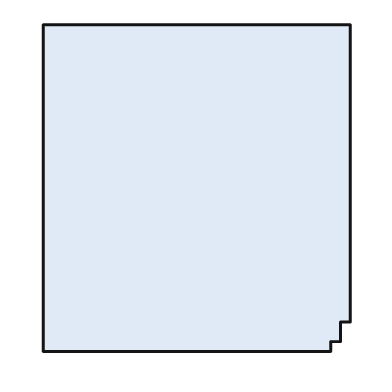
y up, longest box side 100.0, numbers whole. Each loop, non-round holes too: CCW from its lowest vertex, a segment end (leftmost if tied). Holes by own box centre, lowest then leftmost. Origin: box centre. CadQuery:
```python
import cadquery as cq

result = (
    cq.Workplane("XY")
    .moveTo(-47.0, -50.0)
    .lineTo(41.0, -50.0)
    .lineTo(41.0, -47.0)
    .lineTo(44.0, -47.0)
    .lineTo(44.0, -41.0)
    .lineTo(47.0, -41.0)
    .lineTo(47.0, 50.0)
    .lineTo(-47.0, 50.0)
    .close()
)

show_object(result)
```